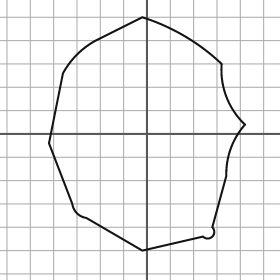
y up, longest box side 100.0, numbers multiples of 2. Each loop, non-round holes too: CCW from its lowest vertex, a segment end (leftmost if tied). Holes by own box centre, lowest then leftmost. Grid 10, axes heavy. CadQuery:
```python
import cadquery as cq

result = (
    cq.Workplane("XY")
    .moveTo(-2.0, -50.0)
    .lineTo(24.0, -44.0)
    .threePointArc((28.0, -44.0), (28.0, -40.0))
    .lineTo(34.0, -18.0)
    .threePointArc((36.0, -6.0), (42.0, 4.0))
    .threePointArc((34.0, 16.0), (32.0, 30.0))
    .threePointArc((16.0, 42.0), (-2.0, 50.0))
    .lineTo(-22.0, 40.0)
    .threePointArc((-30.0, 34.0), (-36.0, 26.0))
    .lineTo(-42.0, -4.0)
    .lineTo(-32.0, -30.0)
    .threePointArc((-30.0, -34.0), (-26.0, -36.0))
    .close()
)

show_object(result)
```